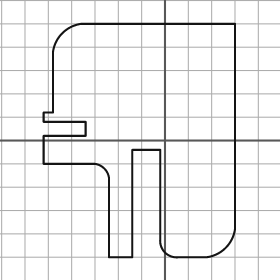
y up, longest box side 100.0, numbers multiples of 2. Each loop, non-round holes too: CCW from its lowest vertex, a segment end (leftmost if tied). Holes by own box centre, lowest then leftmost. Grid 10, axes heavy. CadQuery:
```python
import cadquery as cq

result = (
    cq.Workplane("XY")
    .moveTo(-24.0, -50.0)
    .lineTo(-14.0, -50.0)
    .lineTo(-14.0, -4.0)
    .lineTo(-2.0, -4.0)
    .lineTo(-2.0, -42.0)
    .threePointArc((0.0, -48.0), (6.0, -50.0))
    .lineTo(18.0, -50.0)
    .threePointArc((26.0, -46.0), (30.0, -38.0))
    .lineTo(30.0, 50.0)
    .lineTo(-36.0, 50.0)
    .threePointArc((-44.0, 46.0), (-48.0, 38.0))
    .lineTo(-48.0, 12.0)
    .lineTo(-52.0, 12.0)
    .lineTo(-52.0, 8.0)
    .lineTo(-34.0, 8.0)
    .lineTo(-34.0, 2.0)
    .lineTo(-52.0, 2.0)
    .lineTo(-52.0, -10.0)
    .lineTo(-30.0, -10.0)
    .threePointArc((-26.0, -12.0), (-24.0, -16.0))
    .close()
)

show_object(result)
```